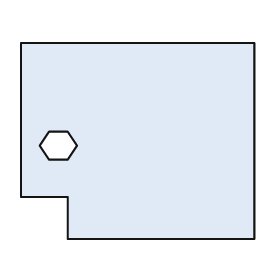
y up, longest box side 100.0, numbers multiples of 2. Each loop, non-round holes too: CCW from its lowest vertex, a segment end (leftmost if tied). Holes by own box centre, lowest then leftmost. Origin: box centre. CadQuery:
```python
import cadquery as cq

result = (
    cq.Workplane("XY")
    .moveTo(-30.0, -42.0)
    .lineTo(50.0, -42.0)
    .lineTo(50.0, 42.0)
    .lineTo(-50.0, 42.0)
    .lineTo(-50.0, -24.0)
    .lineTo(-30.0, -24.0)
    .close()
    .moveTo(-38.0, -8.0)
    .lineTo(-30.0, -8.0)
    .lineTo(-26.0, -2.0)
    .lineTo(-30.0, 4.0)
    .lineTo(-38.0, 4.0)
    .lineTo(-42.0, -2.0)
    .close()
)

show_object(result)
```